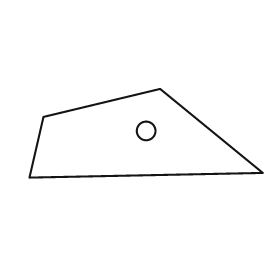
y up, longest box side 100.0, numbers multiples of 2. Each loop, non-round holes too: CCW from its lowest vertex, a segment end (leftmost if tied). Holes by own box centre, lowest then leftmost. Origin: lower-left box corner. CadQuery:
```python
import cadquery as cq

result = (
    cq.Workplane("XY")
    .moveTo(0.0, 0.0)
    .lineTo(100.0, 2.0)
    .lineTo(56.0, 38.0)
    .lineTo(6.0, 26.0)
    .close()
    .moveTo(50.0, 20.0)
    .circle(4.0)
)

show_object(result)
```